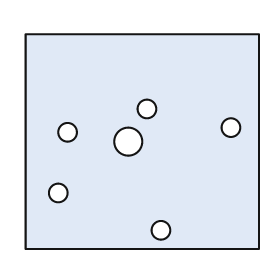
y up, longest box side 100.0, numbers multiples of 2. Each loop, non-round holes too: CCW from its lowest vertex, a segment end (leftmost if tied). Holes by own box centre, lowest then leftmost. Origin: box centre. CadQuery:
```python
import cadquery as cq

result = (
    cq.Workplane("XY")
    .moveTo(-50.0, -46.0)
    .lineTo(50.0, -46.0)
    .lineTo(50.0, 46.0)
    .lineTo(-50.0, 46.0)
    .close()
    .moveTo(8.0, -38.0)
    .circle(4.0)
    .moveTo(-36.0, -22.0)
    .circle(4.0)
    .moveTo(-6.0, 0.0)
    .circle(6.0)
    .moveTo(-32.0, 4.0)
    .circle(4.0)
    .moveTo(38.0, 6.0)
    .circle(4.0)
    .moveTo(2.0, 14.0)
    .circle(4.0)
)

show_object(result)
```